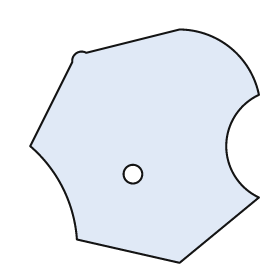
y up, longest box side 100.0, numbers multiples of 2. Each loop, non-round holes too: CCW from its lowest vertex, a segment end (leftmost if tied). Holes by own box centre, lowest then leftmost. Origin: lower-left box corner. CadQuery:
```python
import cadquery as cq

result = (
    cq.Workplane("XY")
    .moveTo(64.0, 0.0)
    .lineTo(98.0, 28.0)
    .threePointArc((84.0, 50.0), (98.0, 72.0))
    .threePointArc((86.0, 92.0), (64.0, 100.0))
    .lineTo(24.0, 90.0)
    .threePointArc((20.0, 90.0), (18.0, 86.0))
    .lineTo(0.0, 50.0)
    .threePointArc((14.0, 32.0), (20.0, 10.0))
    .close()
    .moveTo(44.0, 38.0)
    .circle(4.0)
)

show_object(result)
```